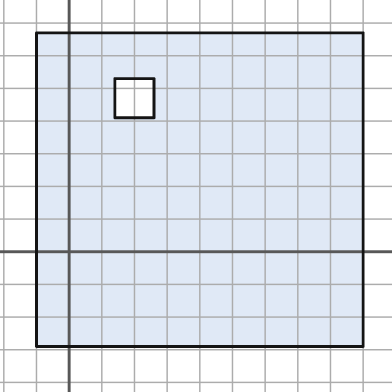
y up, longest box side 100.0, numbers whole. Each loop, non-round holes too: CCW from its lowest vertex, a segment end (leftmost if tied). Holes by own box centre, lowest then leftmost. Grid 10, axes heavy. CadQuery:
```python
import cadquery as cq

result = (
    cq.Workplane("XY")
    .moveTo(-10.0, -29.0)
    .lineTo(90.0, -29.0)
    .lineTo(90.0, 67.0)
    .lineTo(-10.0, 67.0)
    .close()
    .moveTo(14.0, 41.0)
    .lineTo(26.0, 41.0)
    .lineTo(26.0, 53.0)
    .lineTo(14.0, 53.0)
    .close()
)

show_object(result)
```